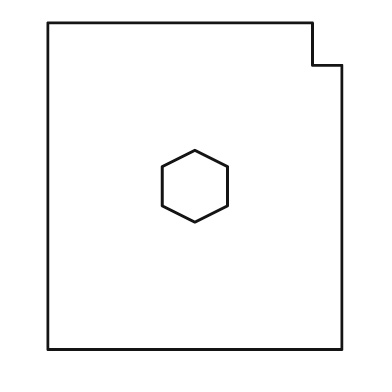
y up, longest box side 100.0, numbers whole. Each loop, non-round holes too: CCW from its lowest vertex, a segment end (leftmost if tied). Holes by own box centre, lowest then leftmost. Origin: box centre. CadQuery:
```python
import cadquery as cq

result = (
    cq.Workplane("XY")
    .moveTo(-45.0, -50.0)
    .lineTo(45.0, -50.0)
    .lineTo(45.0, 37.0)
    .lineTo(36.0, 37.0)
    .lineTo(36.0, 50.0)
    .lineTo(-45.0, 50.0)
    .close()
    .moveTo(0.0, -11.0)
    .lineTo(10.0, -6.0)
    .lineTo(10.0, 6.0)
    .lineTo(0.0, 11.0)
    .lineTo(-10.0, 6.0)
    .lineTo(-10.0, -6.0)
    .close()
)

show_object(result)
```